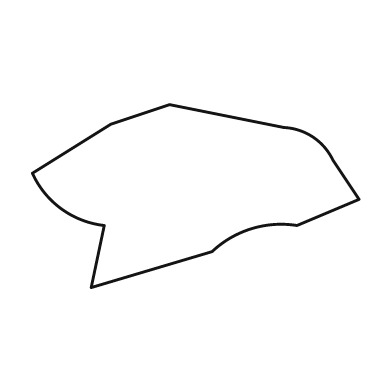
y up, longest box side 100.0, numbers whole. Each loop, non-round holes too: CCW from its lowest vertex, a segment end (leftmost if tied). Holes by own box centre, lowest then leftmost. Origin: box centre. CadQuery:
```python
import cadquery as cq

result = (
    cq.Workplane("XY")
    .moveTo(-32.0, -28.0)
    .lineTo(5.0, -17.0)
    .threePointArc((17.0, -10.0), (31.0, -9.0))
    .lineTo(50.0, -1.0)
    .lineTo(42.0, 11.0)
    .threePointArc((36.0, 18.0), (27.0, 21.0))
    .lineTo(-8.0, 28.0)
    .lineTo(-26.0, 22.0)
    .lineTo(-50.0, 7.0)
    .threePointArc((-41.0, -4.0), (-28.0, -9.0))
    .close()
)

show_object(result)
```